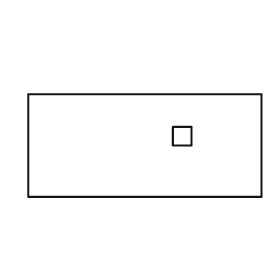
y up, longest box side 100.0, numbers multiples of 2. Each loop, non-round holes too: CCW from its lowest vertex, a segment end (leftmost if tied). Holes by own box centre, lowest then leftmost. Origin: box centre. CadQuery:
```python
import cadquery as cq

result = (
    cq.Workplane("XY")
    .moveTo(-50.0, -22.0)
    .lineTo(50.0, -22.0)
    .lineTo(50.0, 22.0)
    .lineTo(-50.0, 22.0)
    .close()
    .moveTo(12.0, 0.0)
    .lineTo(20.0, 0.0)
    .lineTo(20.0, 8.0)
    .lineTo(12.0, 8.0)
    .close()
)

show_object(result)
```